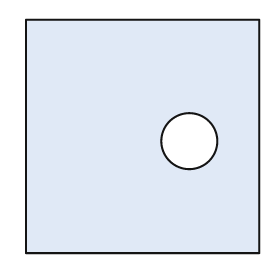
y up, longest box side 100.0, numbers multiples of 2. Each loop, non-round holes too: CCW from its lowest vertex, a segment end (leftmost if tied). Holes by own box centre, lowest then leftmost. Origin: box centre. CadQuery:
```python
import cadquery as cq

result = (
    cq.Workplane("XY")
    .moveTo(-50.0, -50.0)
    .lineTo(50.0, -50.0)
    .lineTo(50.0, 50.0)
    .lineTo(-50.0, 50.0)
    .close()
    .moveTo(20.0, -2.0)
    .circle(12.0)
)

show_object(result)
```